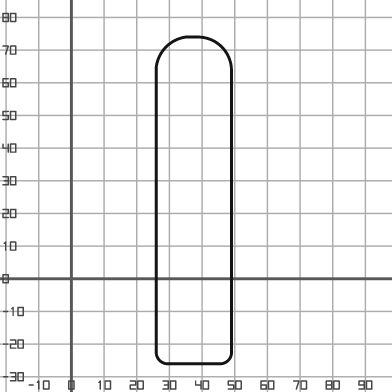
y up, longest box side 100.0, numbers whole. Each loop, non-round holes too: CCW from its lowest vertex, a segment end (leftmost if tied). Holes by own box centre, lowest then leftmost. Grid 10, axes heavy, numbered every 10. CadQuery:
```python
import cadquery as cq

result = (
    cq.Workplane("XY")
    .moveTo(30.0, -26.0)
    .lineTo(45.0, -26.0)
    .threePointArc((48.0, -25.0), (49.0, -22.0))
    .lineTo(49.0, 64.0)
    .threePointArc((46.0, 71.0), (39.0, 74.0))
    .lineTo(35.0, 74.0)
    .threePointArc((29.0, 71.0), (26.0, 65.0))
    .lineTo(26.0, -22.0)
    .threePointArc((27.0, -25.0), (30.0, -26.0))
    .close()
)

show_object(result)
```